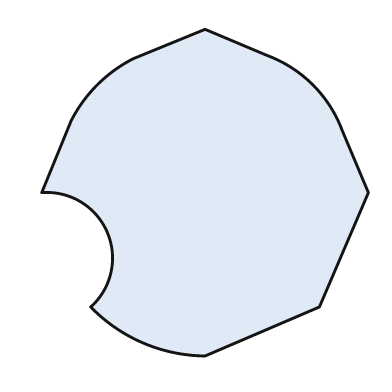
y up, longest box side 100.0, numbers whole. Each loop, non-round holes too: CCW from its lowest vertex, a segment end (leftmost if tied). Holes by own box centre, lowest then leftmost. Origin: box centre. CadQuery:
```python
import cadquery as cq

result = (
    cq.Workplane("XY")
    .moveTo(0.0, -50.0)
    .lineTo(35.0, -35.0)
    .lineTo(50.0, 0.0)
    .lineTo(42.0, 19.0)
    .threePointArc((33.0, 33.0), (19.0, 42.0))
    .lineTo(0.0, 50.0)
    .lineTo(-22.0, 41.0)
    .threePointArc((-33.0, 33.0), (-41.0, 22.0))
    .lineTo(-50.0, 0.0)
    .threePointArc((-30.0, -12.0), (-35.0, -35.0))
    .threePointArc((-19.0, -46.0), (0.0, -50.0))
    .close()
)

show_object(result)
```